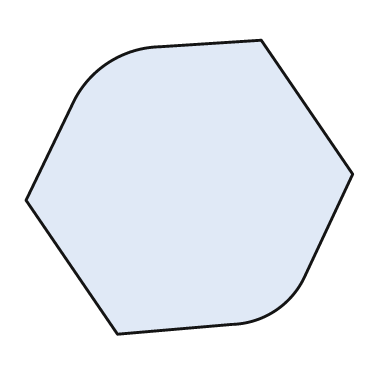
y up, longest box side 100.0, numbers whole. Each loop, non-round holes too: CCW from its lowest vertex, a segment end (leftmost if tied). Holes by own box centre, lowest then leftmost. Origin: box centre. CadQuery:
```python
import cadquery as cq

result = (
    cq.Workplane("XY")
    .moveTo(-22.0, -45.0)
    .lineTo(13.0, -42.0)
    .threePointArc((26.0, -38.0), (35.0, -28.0))
    .lineTo(50.0, 4.0)
    .lineTo(22.0, 45.0)
    .lineTo(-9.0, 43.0)
    .threePointArc((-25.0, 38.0), (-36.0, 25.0))
    .lineTo(-50.0, -4.0)
    .close()
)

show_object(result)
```